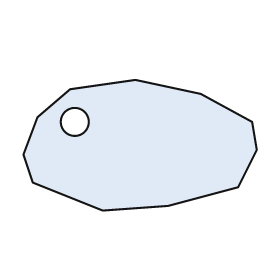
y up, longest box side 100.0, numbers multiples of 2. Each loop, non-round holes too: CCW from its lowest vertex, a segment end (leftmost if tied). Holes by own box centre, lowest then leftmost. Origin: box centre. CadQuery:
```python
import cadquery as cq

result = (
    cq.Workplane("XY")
    .moveTo(-16.0, -28.0)
    .lineTo(12.0, -26.0)
    .lineTo(42.0, -18.0)
    .lineTo(50.0, -2.0)
    .lineTo(48.0, 10.0)
    .lineTo(26.0, 22.0)
    .lineTo(-2.0, 28.0)
    .lineTo(-30.0, 24.0)
    .lineTo(-44.0, 12.0)
    .lineTo(-50.0, -4.0)
    .lineTo(-46.0, -16.0)
    .close()
    .moveTo(-28.0, 10.0)
    .circle(6.0)
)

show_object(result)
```